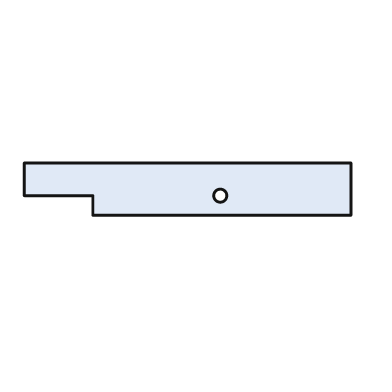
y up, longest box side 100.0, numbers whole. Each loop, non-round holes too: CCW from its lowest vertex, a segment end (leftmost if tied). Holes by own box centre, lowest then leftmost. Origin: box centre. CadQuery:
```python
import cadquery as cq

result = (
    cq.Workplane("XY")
    .moveTo(-29.0, -8.0)
    .lineTo(50.0, -8.0)
    .lineTo(50.0, 8.0)
    .lineTo(-50.0, 8.0)
    .lineTo(-50.0, -2.0)
    .lineTo(-29.0, -2.0)
    .close()
    .moveTo(10.0, -2.0)
    .circle(2.0)
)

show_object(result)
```